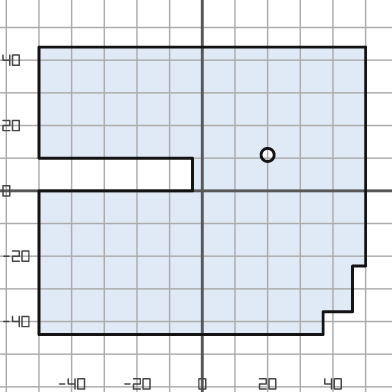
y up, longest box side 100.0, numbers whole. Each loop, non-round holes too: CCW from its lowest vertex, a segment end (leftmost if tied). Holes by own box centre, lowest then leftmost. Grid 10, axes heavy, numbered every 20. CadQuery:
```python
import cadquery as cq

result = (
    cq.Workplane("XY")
    .moveTo(-50.0, -44.0)
    .lineTo(37.0, -44.0)
    .lineTo(37.0, -37.0)
    .lineTo(46.0, -37.0)
    .lineTo(46.0, -23.0)
    .lineTo(50.0, -23.0)
    .lineTo(50.0, 44.0)
    .lineTo(-50.0, 44.0)
    .lineTo(-50.0, 10.0)
    .lineTo(-3.0, 10.0)
    .lineTo(-3.0, 0.0)
    .lineTo(-50.0, 0.0)
    .close()
    .moveTo(20.0, 11.0)
    .circle(2.0)
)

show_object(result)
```